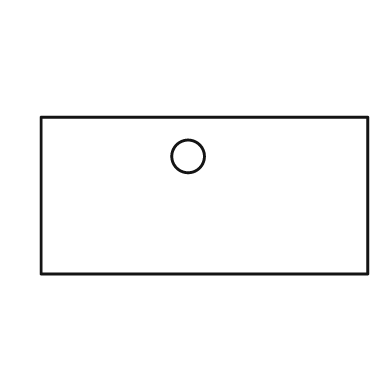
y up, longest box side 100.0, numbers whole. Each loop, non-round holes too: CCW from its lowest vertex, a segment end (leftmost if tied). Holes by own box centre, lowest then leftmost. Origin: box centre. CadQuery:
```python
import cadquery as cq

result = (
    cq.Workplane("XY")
    .moveTo(-50.0, -24.0)
    .lineTo(50.0, -24.0)
    .lineTo(50.0, 24.0)
    .lineTo(-50.0, 24.0)
    .close()
    .moveTo(-5.0, 12.0)
    .circle(5.0)
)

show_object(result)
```